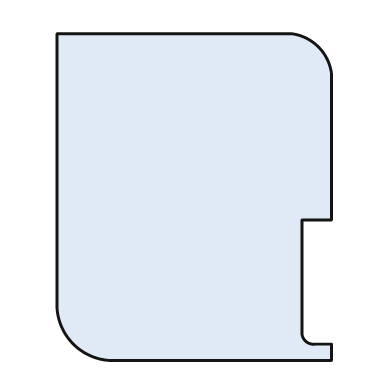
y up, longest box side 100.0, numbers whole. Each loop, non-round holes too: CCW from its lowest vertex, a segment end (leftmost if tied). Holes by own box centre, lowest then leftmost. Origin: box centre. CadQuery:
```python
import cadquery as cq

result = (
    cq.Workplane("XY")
    .moveTo(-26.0, -50.0)
    .lineTo(42.0, -50.0)
    .lineTo(42.0, -45.0)
    .lineTo(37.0, -45.0)
    .threePointArc((34.0, -44.0), (33.0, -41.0))
    .lineTo(33.0, -7.0)
    .lineTo(42.0, -7.0)
    .lineTo(42.0, 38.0)
    .threePointArc((38.0, 46.0), (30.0, 50.0))
    .lineTo(-42.0, 50.0)
    .lineTo(-42.0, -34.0)
    .threePointArc((-37.0, -45.0), (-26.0, -50.0))
    .close()
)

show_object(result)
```